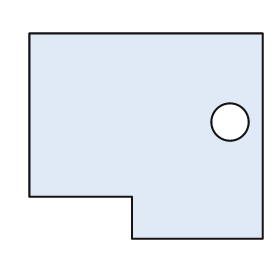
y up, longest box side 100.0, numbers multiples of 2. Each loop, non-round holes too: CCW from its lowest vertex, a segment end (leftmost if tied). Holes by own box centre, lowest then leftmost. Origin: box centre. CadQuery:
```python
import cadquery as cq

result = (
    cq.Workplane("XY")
    .moveTo(-6.0, -44.0)
    .lineTo(50.0, -44.0)
    .lineTo(50.0, 44.0)
    .lineTo(-50.0, 44.0)
    .lineTo(-50.0, -26.0)
    .lineTo(-6.0, -26.0)
    .close()
    .moveTo(36.0, 6.0)
    .circle(8.0)
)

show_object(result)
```